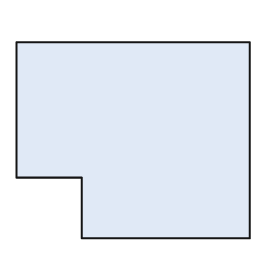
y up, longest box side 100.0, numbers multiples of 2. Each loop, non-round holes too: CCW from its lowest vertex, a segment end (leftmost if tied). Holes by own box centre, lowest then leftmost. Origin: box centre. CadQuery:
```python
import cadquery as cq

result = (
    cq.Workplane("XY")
    .moveTo(-22.0, -42.0)
    .lineTo(50.0, -42.0)
    .lineTo(50.0, 42.0)
    .lineTo(-50.0, 42.0)
    .lineTo(-50.0, -16.0)
    .lineTo(-22.0, -16.0)
    .close()
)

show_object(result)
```